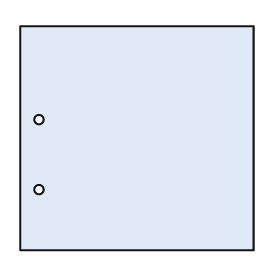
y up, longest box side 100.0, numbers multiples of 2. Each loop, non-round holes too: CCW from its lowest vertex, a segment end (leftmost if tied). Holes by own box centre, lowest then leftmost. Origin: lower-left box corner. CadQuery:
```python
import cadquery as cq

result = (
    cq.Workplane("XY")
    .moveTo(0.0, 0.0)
    .lineTo(100.0, 0.0)
    .lineTo(100.0, 96.0)
    .lineTo(0.0, 96.0)
    .close()
    .moveTo(8.0, 26.0)
    .circle(2.0)
    .moveTo(8.0, 56.0)
    .circle(2.0)
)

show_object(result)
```